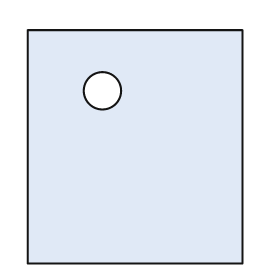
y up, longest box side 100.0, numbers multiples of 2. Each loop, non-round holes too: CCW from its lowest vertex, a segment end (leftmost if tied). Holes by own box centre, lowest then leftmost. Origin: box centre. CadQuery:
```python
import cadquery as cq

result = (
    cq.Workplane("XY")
    .moveTo(-46.0, -50.0)
    .lineTo(46.0, -50.0)
    .lineTo(46.0, 50.0)
    .lineTo(-46.0, 50.0)
    .close()
    .moveTo(-14.0, 24.0)
    .circle(8.0)
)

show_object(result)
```